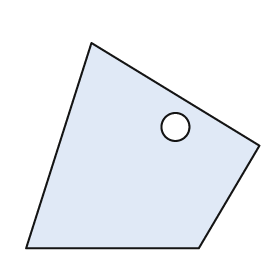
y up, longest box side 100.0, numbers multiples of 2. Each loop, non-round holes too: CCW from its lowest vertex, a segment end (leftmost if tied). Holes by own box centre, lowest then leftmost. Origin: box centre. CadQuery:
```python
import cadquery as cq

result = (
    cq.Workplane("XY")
    .moveTo(-50.0, -44.0)
    .lineTo(24.0, -44.0)
    .lineTo(50.0, 0.0)
    .lineTo(-22.0, 44.0)
    .close()
    .moveTo(14.0, 8.0)
    .circle(6.0)
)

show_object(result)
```